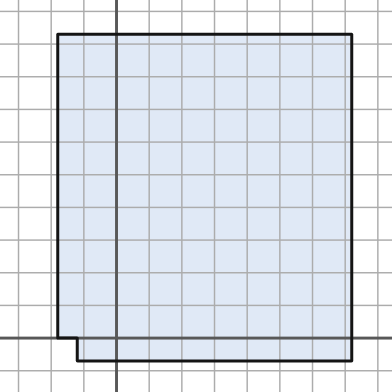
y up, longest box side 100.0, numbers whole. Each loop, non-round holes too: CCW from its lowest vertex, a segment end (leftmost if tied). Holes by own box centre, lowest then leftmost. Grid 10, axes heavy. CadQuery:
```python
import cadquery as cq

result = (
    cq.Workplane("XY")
    .moveTo(-12.0, -7.0)
    .lineTo(72.0, -7.0)
    .lineTo(72.0, 93.0)
    .lineTo(-18.0, 93.0)
    .lineTo(-18.0, 0.0)
    .lineTo(-12.0, 0.0)
    .close()
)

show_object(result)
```